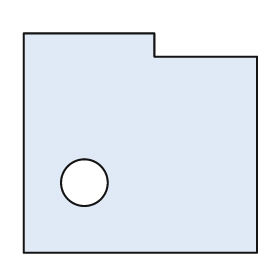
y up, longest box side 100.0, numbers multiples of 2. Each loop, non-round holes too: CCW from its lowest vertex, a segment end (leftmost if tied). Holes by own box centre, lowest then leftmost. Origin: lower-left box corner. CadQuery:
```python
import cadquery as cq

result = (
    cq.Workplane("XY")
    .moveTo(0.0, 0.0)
    .lineTo(100.0, 0.0)
    .lineTo(100.0, 84.0)
    .lineTo(56.0, 84.0)
    .lineTo(56.0, 94.0)
    .lineTo(0.0, 94.0)
    .close()
    .moveTo(26.0, 30.0)
    .circle(10.0)
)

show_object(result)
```